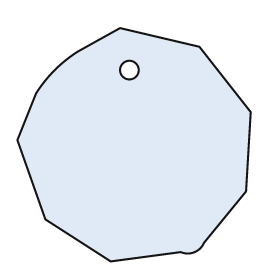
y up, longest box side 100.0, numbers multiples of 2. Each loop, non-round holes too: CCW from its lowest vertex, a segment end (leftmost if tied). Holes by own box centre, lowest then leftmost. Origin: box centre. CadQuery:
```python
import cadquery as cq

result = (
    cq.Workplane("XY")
    .moveTo(-10.0, -50.0)
    .lineTo(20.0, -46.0)
    .threePointArc((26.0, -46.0), (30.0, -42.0))
    .lineTo(48.0, -20.0)
    .lineTo(50.0, 14.0)
    .lineTo(28.0, 42.0)
    .lineTo(-6.0, 50.0)
    .lineTo(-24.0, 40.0)
    .threePointArc((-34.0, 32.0), (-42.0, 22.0))
    .lineTo(-50.0, 2.0)
    .lineTo(-38.0, -32.0)
    .close()
    .moveTo(-2.0, 32.0)
    .circle(4.0)
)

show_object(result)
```